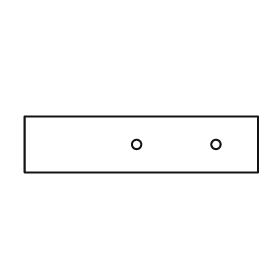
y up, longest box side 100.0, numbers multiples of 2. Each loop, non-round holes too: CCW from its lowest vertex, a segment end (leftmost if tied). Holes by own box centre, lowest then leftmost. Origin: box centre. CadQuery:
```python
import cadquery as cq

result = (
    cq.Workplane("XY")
    .moveTo(-50.0, -12.0)
    .lineTo(50.0, -12.0)
    .lineTo(50.0, 12.0)
    .lineTo(-50.0, 12.0)
    .close()
    .moveTo(-2.0, 0.0)
    .circle(2.0)
    .moveTo(32.0, 0.0)
    .circle(2.0)
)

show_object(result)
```